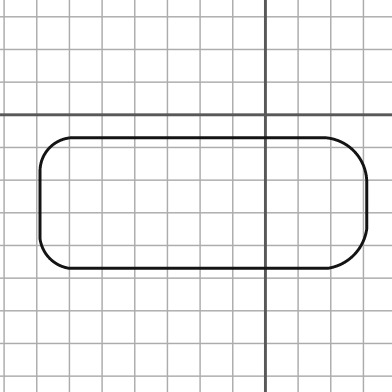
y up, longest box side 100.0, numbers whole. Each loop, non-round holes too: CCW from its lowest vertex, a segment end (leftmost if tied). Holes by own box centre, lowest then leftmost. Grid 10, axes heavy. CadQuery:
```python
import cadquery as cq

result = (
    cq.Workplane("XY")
    .moveTo(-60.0, -47.0)
    .lineTo(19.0, -47.0)
    .threePointArc((27.0, -43.0), (31.0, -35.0))
    .lineTo(31.0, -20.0)
    .threePointArc((27.0, -11.0), (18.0, -7.0))
    .lineTo(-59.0, -7.0)
    .threePointArc((-66.0, -10.0), (-69.0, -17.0))
    .lineTo(-69.0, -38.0)
    .threePointArc((-66.0, -44.0), (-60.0, -47.0))
    .close()
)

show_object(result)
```